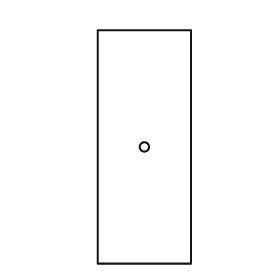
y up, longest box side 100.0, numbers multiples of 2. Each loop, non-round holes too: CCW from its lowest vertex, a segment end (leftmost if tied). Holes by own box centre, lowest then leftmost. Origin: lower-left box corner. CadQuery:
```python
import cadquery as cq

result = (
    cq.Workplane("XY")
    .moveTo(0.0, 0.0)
    .lineTo(40.0, 0.0)
    .lineTo(40.0, 100.0)
    .lineTo(0.0, 100.0)
    .close()
    .moveTo(20.0, 50.0)
    .circle(2.0)
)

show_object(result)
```